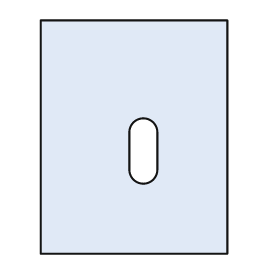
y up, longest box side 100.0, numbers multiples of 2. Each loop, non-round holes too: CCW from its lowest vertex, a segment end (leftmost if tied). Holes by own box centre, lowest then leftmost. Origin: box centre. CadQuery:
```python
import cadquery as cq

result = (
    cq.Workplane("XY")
    .moveTo(-40.0, -50.0)
    .lineTo(40.0, -50.0)
    .lineTo(40.0, 50.0)
    .lineTo(-40.0, 50.0)
    .close()
    .moveTo(-2.0, -14.0)
    .threePointArc((4.0, -20.0), (10.0, -14.0))
    .lineTo(10.0, 2.0)
    .threePointArc((4.0, 8.0), (-2.0, 2.0))
    .close()
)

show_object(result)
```